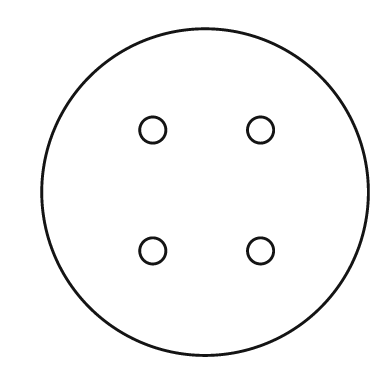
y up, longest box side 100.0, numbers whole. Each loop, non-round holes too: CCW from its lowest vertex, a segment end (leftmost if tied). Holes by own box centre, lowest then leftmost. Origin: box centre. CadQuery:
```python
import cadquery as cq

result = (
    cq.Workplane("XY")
    .moveTo(0.0, 0.0)
    .circle(50.0)
    .moveTo(-16.0, -18.0)
    .circle(4.0)
    .moveTo(17.0, -18.0)
    .circle(4.0)
    .moveTo(-16.0, 19.0)
    .circle(4.0)
    .moveTo(17.0, 19.0)
    .circle(4.0)
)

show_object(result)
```